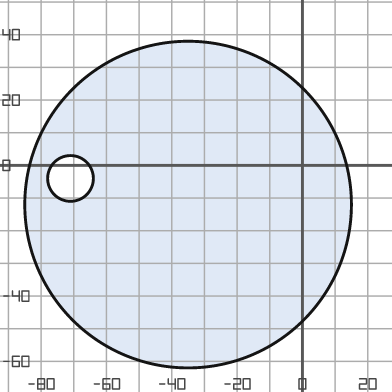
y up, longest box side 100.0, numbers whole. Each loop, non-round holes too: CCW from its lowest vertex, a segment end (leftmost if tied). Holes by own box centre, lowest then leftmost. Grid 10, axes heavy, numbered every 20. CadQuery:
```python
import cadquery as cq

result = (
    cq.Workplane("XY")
    .moveTo(-35.0, -12.0)
    .circle(50.0)
    .moveTo(-71.0, -4.0)
    .circle(7.0)
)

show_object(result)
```